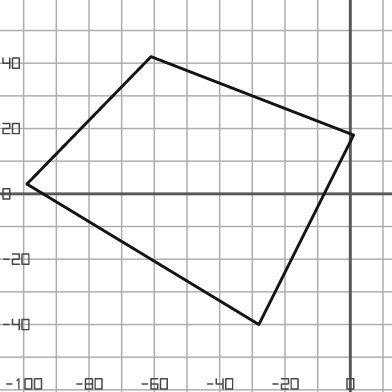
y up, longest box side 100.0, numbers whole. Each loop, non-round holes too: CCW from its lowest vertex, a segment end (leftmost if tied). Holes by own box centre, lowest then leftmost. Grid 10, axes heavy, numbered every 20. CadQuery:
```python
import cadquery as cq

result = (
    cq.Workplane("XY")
    .moveTo(-28.0, -40.0)
    .lineTo(1.0, 18.0)
    .lineTo(-61.0, 42.0)
    .lineTo(-99.0, 3.0)
    .close()
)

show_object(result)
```